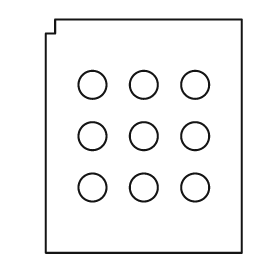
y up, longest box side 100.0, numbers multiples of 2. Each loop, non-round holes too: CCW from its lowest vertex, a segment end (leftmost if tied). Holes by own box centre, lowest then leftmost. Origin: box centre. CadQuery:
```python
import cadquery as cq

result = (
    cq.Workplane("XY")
    .moveTo(-42.0, -50.0)
    .lineTo(42.0, -50.0)
    .lineTo(42.0, 50.0)
    .lineTo(-38.0, 50.0)
    .lineTo(-38.0, 44.0)
    .lineTo(-42.0, 44.0)
    .close()
    .moveTo(-22.0, -22.0)
    .circle(6.0)
    .moveTo(0.0, -22.0)
    .circle(6.0)
    .moveTo(22.0, -22.0)
    .circle(6.0)
    .moveTo(-22.0, 0.0)
    .circle(6.0)
    .moveTo(0.0, 0.0)
    .circle(6.0)
    .moveTo(22.0, 0.0)
    .circle(6.0)
    .moveTo(-22.0, 22.0)
    .circle(6.0)
    .moveTo(0.0, 22.0)
    .circle(6.0)
    .moveTo(22.0, 22.0)
    .circle(6.0)
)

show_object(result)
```